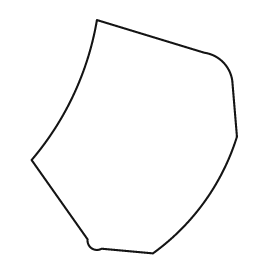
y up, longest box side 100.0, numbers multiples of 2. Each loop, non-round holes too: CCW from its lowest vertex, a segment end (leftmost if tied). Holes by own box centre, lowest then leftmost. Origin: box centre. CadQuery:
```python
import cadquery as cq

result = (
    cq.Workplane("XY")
    .moveTo(8.0, -50.0)
    .threePointArc((30.0, -28.0), (44.0, 0.0))
    .lineTo(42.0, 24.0)
    .threePointArc((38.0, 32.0), (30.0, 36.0))
    .lineTo(-16.0, 50.0)
    .threePointArc((-26.0, 18.0), (-44.0, -10.0))
    .lineTo(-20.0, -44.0)
    .threePointArc((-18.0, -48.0), (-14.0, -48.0))
    .close()
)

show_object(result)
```